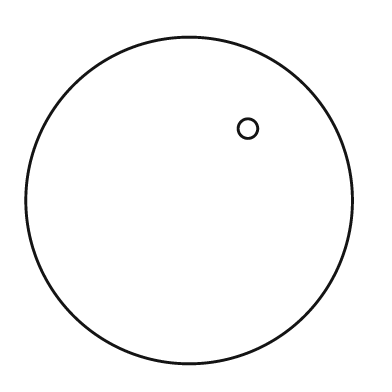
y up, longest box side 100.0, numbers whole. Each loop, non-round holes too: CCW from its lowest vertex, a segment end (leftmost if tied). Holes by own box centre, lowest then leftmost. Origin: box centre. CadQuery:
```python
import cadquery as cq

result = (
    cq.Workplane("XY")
    .moveTo(0.0, 0.0)
    .circle(50.0)
    .moveTo(18.0, 22.0)
    .circle(3.0)
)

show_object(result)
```